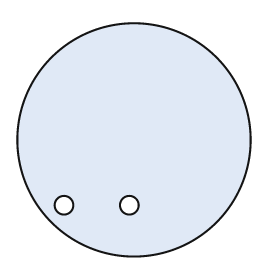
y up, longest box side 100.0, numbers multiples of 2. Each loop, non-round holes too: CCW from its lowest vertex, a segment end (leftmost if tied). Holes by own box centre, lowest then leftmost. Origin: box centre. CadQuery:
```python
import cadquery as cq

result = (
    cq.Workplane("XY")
    .moveTo(0.0, 0.0)
    .circle(50.0)
    .moveTo(-30.0, -28.0)
    .circle(4.0)
    .moveTo(-2.0, -28.0)
    .circle(4.0)
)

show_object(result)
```